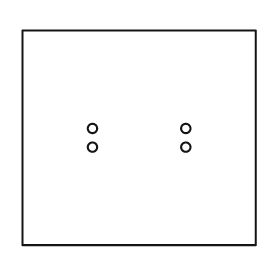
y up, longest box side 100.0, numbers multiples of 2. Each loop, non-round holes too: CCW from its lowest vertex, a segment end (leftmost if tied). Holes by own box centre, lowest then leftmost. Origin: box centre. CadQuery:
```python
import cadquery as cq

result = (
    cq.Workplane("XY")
    .moveTo(-50.0, -46.0)
    .lineTo(50.0, -46.0)
    .lineTo(50.0, 46.0)
    .lineTo(-50.0, 46.0)
    .close()
    .moveTo(-20.0, -4.0)
    .circle(2.0)
    .moveTo(20.0, -4.0)
    .circle(2.0)
    .moveTo(-20.0, 4.0)
    .circle(2.0)
    .moveTo(20.0, 4.0)
    .circle(2.0)
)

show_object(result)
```